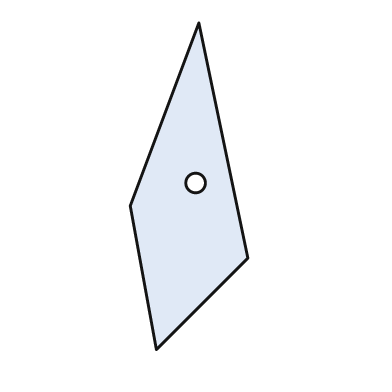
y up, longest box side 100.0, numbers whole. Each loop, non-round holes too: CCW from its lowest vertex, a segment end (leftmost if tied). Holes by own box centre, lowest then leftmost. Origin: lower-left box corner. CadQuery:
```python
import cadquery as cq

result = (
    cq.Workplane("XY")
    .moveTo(8.0, 0.0)
    .lineTo(36.0, 28.0)
    .lineTo(21.0, 100.0)
    .lineTo(0.0, 44.0)
    .close()
    .moveTo(20.0, 51.0)
    .circle(3.0)
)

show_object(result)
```